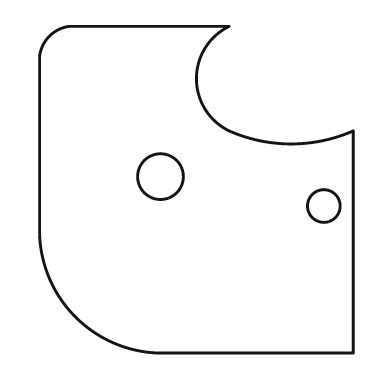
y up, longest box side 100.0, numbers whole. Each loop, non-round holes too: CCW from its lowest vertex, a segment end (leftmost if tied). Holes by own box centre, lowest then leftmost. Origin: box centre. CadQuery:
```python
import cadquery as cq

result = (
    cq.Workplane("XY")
    .moveTo(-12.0, -50.0)
    .lineTo(48.0, -50.0)
    .lineTo(48.0, 18.0)
    .threePointArc((29.0, 14.0), (10.0, 18.0))
    .threePointArc((0.0, 34.0), (10.0, 50.0))
    .lineTo(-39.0, 50.0)
    .threePointArc((-45.0, 47.0), (-48.0, 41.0))
    .lineTo(-48.0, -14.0)
    .threePointArc((-37.0, -39.0), (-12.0, -50.0))
    .close()
    .moveTo(39.0, -5.0)
    .circle(5.0)
    .moveTo(-11.0, 4.0)
    .circle(7.0)
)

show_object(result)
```